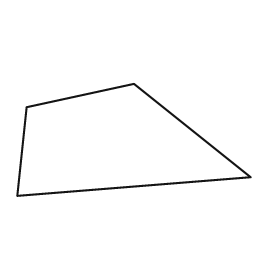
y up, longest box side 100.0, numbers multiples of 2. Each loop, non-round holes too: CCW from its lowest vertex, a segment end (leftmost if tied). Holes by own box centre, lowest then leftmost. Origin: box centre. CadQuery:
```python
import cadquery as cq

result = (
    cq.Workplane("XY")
    .moveTo(-50.0, -24.0)
    .lineTo(50.0, -16.0)
    .lineTo(0.0, 24.0)
    .lineTo(-46.0, 14.0)
    .close()
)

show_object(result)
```